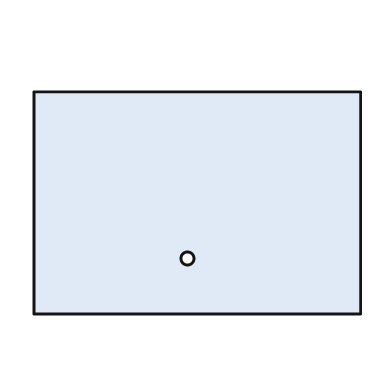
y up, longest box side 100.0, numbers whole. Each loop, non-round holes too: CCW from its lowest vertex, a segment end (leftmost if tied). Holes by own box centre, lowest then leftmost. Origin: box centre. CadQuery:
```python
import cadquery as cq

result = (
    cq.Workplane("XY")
    .moveTo(-50.0, -34.0)
    .lineTo(50.0, -34.0)
    .lineTo(50.0, 34.0)
    .lineTo(-50.0, 34.0)
    .close()
    .moveTo(-3.0, -17.0)
    .circle(2.0)
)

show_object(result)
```